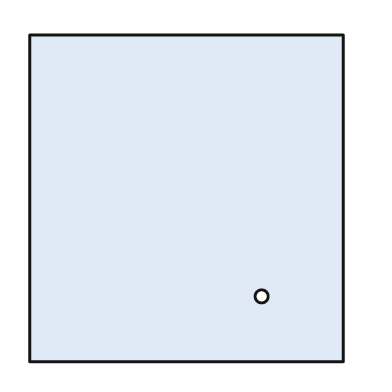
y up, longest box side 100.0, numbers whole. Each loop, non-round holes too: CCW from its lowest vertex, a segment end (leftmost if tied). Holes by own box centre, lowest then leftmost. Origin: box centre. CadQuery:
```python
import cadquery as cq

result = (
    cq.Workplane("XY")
    .moveTo(-48.0, -50.0)
    .lineTo(48.0, -50.0)
    .lineTo(48.0, 50.0)
    .lineTo(-48.0, 50.0)
    .close()
    .moveTo(23.0, -30.0)
    .circle(2.0)
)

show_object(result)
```